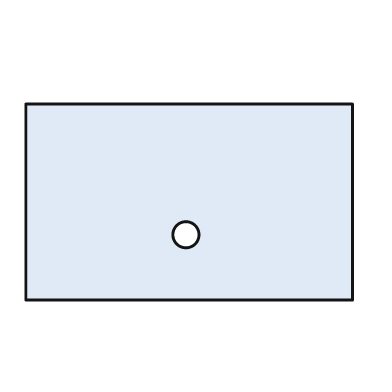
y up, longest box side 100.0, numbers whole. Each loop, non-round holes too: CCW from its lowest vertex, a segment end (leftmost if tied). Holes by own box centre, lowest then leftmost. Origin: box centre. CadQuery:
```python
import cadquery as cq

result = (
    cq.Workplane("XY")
    .moveTo(-50.0, -30.0)
    .lineTo(50.0, -30.0)
    .lineTo(50.0, 30.0)
    .lineTo(-50.0, 30.0)
    .close()
    .moveTo(-1.0, -10.0)
    .circle(4.0)
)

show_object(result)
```